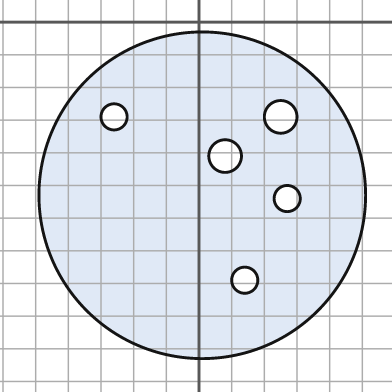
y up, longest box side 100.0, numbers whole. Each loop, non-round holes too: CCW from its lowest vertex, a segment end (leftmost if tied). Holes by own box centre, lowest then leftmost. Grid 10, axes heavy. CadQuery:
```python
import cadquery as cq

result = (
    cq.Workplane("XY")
    .moveTo(1.0, -53.0)
    .circle(50.0)
    .moveTo(14.0, -79.0)
    .circle(4.0)
    .moveTo(27.0, -54.0)
    .circle(4.0)
    .moveTo(8.0, -41.0)
    .circle(5.0)
    .moveTo(-26.0, -29.0)
    .circle(4.0)
    .moveTo(25.0, -29.0)
    .circle(5.0)
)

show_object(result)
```